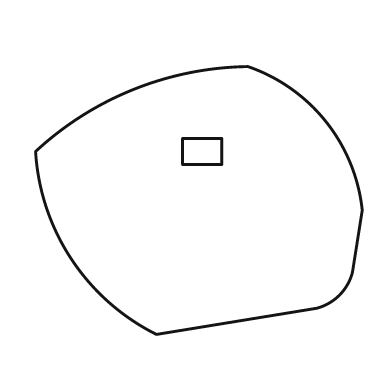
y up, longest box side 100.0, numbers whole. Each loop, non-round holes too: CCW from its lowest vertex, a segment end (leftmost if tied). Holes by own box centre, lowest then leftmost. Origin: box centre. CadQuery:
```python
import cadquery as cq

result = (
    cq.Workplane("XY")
    .moveTo(-13.0, -41.0)
    .lineTo(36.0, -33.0)
    .threePointArc((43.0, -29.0), (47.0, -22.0))
    .lineTo(50.0, -3.0)
    .threePointArc((39.0, 24.0), (15.0, 41.0))
    .threePointArc((-20.0, 34.0), (-50.0, 15.0))
    .threePointArc((-39.0, -18.0), (-13.0, -41.0))
    .close()
    .moveTo(-5.0, 11.0)
    .lineTo(7.0, 11.0)
    .lineTo(7.0, 19.0)
    .lineTo(-5.0, 19.0)
    .close()
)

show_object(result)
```